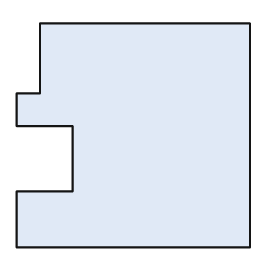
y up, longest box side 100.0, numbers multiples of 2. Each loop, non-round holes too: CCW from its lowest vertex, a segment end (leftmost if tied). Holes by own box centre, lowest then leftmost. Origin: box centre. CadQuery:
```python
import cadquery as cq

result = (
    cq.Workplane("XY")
    .moveTo(-50.0, -48.0)
    .lineTo(50.0, -48.0)
    .lineTo(50.0, 48.0)
    .lineTo(-40.0, 48.0)
    .lineTo(-40.0, 18.0)
    .lineTo(-50.0, 18.0)
    .lineTo(-50.0, 4.0)
    .lineTo(-26.0, 4.0)
    .lineTo(-26.0, -24.0)
    .lineTo(-50.0, -24.0)
    .close()
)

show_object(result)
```